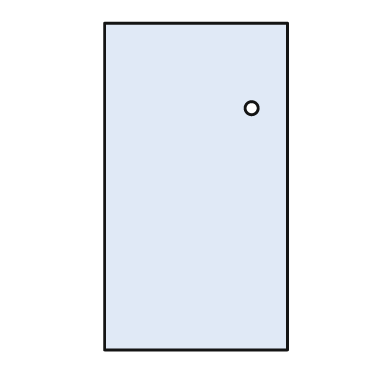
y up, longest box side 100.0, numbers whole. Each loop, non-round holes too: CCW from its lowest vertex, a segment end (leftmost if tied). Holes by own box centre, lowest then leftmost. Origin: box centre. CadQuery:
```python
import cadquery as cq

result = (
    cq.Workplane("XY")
    .moveTo(-28.0, -50.0)
    .lineTo(28.0, -50.0)
    .lineTo(28.0, 50.0)
    .lineTo(-28.0, 50.0)
    .close()
    .moveTo(17.0, 24.0)
    .circle(2.0)
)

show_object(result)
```